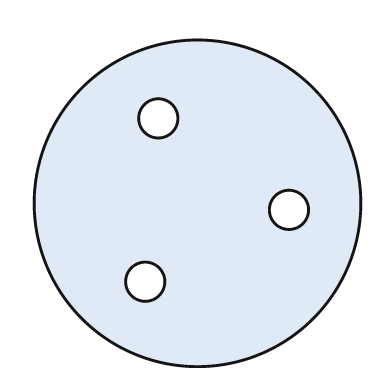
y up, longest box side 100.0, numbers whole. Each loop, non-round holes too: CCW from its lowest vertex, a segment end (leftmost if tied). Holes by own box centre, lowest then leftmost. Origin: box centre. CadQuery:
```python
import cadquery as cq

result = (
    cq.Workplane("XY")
    .moveTo(0.0, 0.0)
    .circle(50.0)
    .moveTo(-16.0, -24.0)
    .circle(6.0)
    .moveTo(28.0, -2.0)
    .circle(6.0)
    .moveTo(-12.0, 26.0)
    .circle(6.0)
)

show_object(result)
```